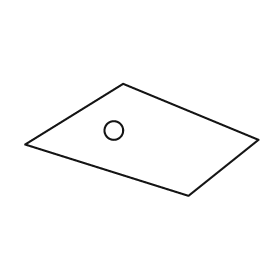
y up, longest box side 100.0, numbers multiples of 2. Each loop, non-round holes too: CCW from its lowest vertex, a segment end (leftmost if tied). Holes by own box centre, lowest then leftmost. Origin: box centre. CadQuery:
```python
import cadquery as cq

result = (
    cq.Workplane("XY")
    .moveTo(20.0, -24.0)
    .lineTo(50.0, 0.0)
    .lineTo(-8.0, 24.0)
    .lineTo(-50.0, -2.0)
    .close()
    .moveTo(-12.0, 4.0)
    .circle(4.0)
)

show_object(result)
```